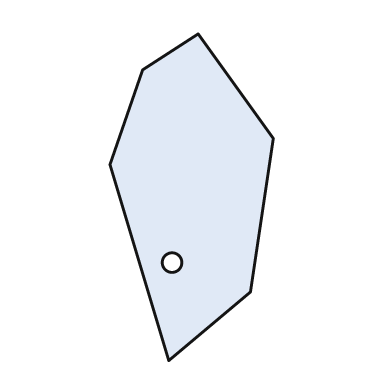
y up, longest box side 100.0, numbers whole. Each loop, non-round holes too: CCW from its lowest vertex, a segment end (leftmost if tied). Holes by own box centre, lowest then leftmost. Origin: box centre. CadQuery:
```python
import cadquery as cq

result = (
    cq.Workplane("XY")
    .moveTo(-7.0, -50.0)
    .lineTo(18.0, -29.0)
    .lineTo(25.0, 18.0)
    .lineTo(2.0, 50.0)
    .lineTo(-15.0, 39.0)
    .lineTo(-25.0, 10.0)
    .close()
    .moveTo(-6.0, -20.0)
    .circle(3.0)
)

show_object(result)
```